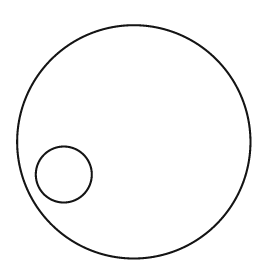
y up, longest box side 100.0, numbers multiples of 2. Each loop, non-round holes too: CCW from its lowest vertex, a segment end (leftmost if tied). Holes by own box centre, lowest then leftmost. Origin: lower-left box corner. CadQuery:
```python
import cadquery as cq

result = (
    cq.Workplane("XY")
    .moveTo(50.0, 50.0)
    .circle(50.0)
    .moveTo(20.0, 36.0)
    .circle(12.0)
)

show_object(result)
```